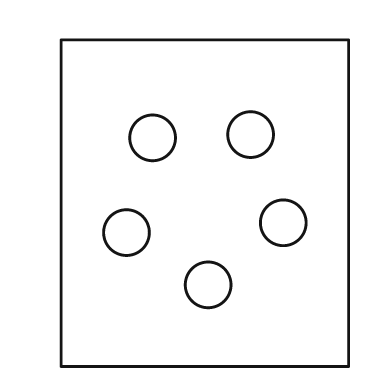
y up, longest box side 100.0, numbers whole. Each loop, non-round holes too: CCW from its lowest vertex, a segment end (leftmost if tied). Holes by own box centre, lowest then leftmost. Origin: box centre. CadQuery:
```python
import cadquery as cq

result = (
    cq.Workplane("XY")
    .moveTo(-44.0, -50.0)
    .lineTo(44.0, -50.0)
    .lineTo(44.0, 50.0)
    .lineTo(-44.0, 50.0)
    .close()
    .moveTo(1.0, -25.0)
    .circle(7.0)
    .moveTo(-24.0, -9.0)
    .circle(7.0)
    .moveTo(24.0, -6.0)
    .circle(7.0)
    .moveTo(-16.0, 20.0)
    .circle(7.0)
    .moveTo(14.0, 21.0)
    .circle(7.0)
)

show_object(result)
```